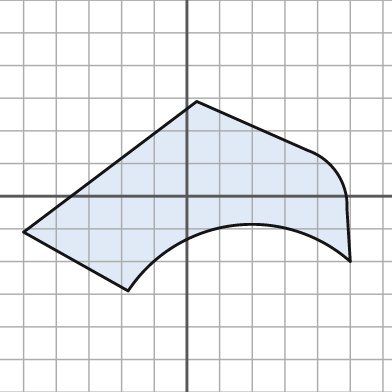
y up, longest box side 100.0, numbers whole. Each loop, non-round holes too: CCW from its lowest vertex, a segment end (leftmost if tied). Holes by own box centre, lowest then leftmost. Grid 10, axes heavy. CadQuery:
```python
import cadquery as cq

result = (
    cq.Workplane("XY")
    .moveTo(-18.0, -29.0)
    .threePointArc((14.0, -9.0), (50.0, -20.0))
    .lineTo(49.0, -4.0)
    .threePointArc((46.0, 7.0), (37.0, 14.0))
    .lineTo(3.0, 29.0)
    .lineTo(-50.0, -11.0)
    .close()
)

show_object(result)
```